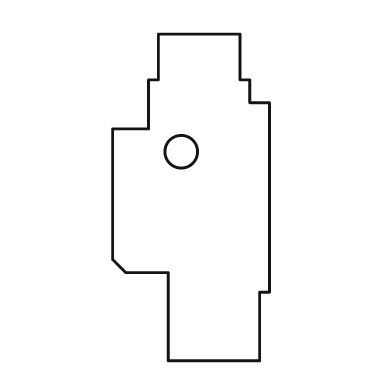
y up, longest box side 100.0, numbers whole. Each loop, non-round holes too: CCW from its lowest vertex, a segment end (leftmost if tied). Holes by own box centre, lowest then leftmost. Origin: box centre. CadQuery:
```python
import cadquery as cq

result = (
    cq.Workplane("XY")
    .moveTo(-7.0, -50.0)
    .lineTo(21.0, -50.0)
    .lineTo(21.0, -29.0)
    .lineTo(24.0, -29.0)
    .lineTo(24.0, 29.0)
    .lineTo(18.0, 29.0)
    .lineTo(18.0, 36.0)
    .lineTo(15.0, 36.0)
    .lineTo(15.0, 50.0)
    .lineTo(-10.0, 50.0)
    .lineTo(-10.0, 36.0)
    .lineTo(-13.0, 36.0)
    .lineTo(-13.0, 21.0)
    .lineTo(-24.0, 21.0)
    .lineTo(-24.0, -19.0)
    .lineTo(-20.0, -23.0)
    .lineTo(-7.0, -23.0)
    .close()
    .moveTo(-3.0, 14.0)
    .circle(5.0)
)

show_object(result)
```